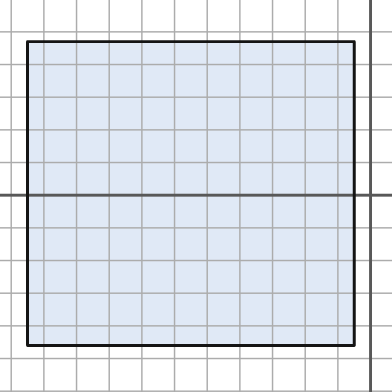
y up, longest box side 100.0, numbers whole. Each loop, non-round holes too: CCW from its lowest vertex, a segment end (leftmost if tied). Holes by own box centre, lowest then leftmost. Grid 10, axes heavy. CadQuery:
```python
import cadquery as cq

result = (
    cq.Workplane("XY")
    .moveTo(-105.0, -46.0)
    .lineTo(-5.0, -46.0)
    .lineTo(-5.0, 47.0)
    .lineTo(-105.0, 47.0)
    .close()
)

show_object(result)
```